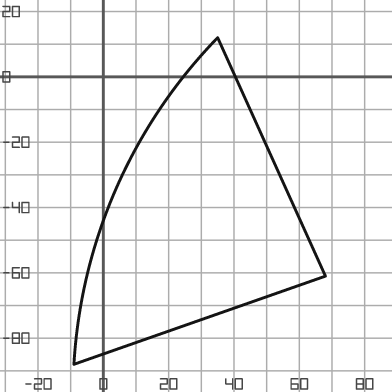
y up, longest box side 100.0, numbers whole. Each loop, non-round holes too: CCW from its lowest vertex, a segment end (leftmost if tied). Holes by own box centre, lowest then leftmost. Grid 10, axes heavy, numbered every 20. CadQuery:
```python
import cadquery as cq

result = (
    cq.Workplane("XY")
    .moveTo(-9.0, -88.0)
    .lineTo(68.0, -61.0)
    .lineTo(35.0, 12.0)
    .threePointArc((4.0, -34.0), (-9.0, -88.0))
    .close()
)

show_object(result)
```